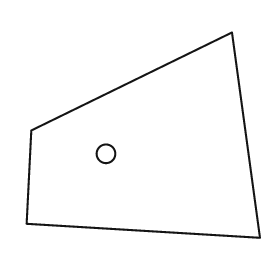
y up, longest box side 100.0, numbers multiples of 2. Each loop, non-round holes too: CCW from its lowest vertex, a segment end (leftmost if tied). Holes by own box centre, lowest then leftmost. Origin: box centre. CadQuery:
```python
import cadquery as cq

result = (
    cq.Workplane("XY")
    .moveTo(50.0, -44.0)
    .lineTo(38.0, 44.0)
    .lineTo(-48.0, 2.0)
    .lineTo(-50.0, -38.0)
    .close()
    .moveTo(-16.0, -8.0)
    .circle(4.0)
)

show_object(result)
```